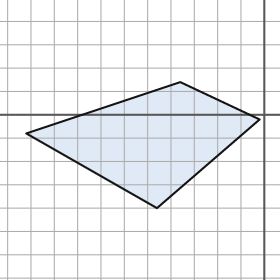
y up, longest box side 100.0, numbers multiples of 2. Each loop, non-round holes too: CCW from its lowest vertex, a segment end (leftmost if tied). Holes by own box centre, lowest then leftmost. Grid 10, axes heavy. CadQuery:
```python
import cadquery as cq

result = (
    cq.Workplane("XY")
    .moveTo(-46.0, -40.0)
    .lineTo(-2.0, -2.0)
    .lineTo(-36.0, 14.0)
    .lineTo(-102.0, -8.0)
    .close()
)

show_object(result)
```